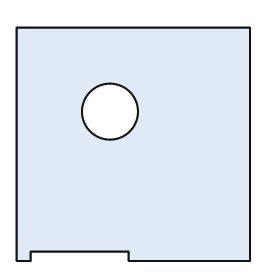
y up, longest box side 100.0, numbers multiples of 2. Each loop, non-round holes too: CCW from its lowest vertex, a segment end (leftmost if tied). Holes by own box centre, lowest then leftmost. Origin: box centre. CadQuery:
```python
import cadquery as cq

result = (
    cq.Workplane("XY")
    .moveTo(-50.0, -50.0)
    .lineTo(-44.0, -50.0)
    .lineTo(-44.0, -46.0)
    .lineTo(-2.0, -46.0)
    .lineTo(-2.0, -50.0)
    .lineTo(50.0, -50.0)
    .lineTo(50.0, 50.0)
    .lineTo(-50.0, 50.0)
    .close()
    .moveTo(-10.0, 14.0)
    .circle(12.0)
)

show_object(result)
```